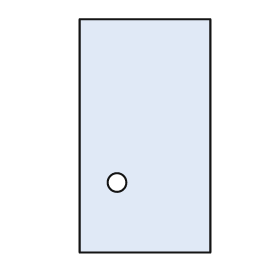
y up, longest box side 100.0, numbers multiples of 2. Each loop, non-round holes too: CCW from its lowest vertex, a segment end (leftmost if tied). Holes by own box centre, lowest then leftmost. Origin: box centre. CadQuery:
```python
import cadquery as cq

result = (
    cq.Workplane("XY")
    .moveTo(-28.0, -50.0)
    .lineTo(28.0, -50.0)
    .lineTo(28.0, 50.0)
    .lineTo(-28.0, 50.0)
    .close()
    .moveTo(-12.0, -20.0)
    .circle(4.0)
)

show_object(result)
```